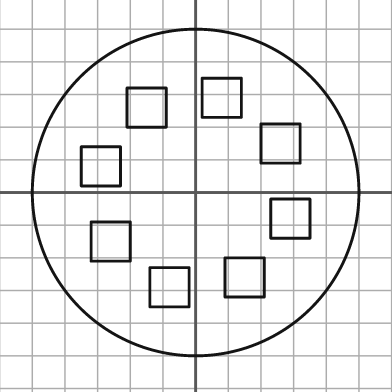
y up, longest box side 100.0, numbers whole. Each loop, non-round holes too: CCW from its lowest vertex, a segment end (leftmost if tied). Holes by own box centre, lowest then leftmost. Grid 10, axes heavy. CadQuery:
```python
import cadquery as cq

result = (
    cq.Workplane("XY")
    .moveTo(0.0, 0.0)
    .circle(50.0)
    .moveTo(-14.0, -35.0)
    .lineTo(-2.0, -35.0)
    .lineTo(-2.0, -23.0)
    .lineTo(-14.0, -23.0)
    .close()
    .moveTo(9.0, -32.0)
    .lineTo(21.0, -32.0)
    .lineTo(21.0, -20.0)
    .lineTo(9.0, -20.0)
    .close()
    .moveTo(-32.0, -21.0)
    .lineTo(-20.0, -21.0)
    .lineTo(-20.0, -9.0)
    .lineTo(-32.0, -9.0)
    .close()
    .moveTo(23.0, -14.0)
    .lineTo(35.0, -14.0)
    .lineTo(35.0, -2.0)
    .lineTo(23.0, -2.0)
    .close()
    .moveTo(-35.0, 2.0)
    .lineTo(-23.0, 2.0)
    .lineTo(-23.0, 14.0)
    .lineTo(-35.0, 14.0)
    .close()
    .moveTo(20.0, 9.0)
    .lineTo(32.0, 9.0)
    .lineTo(32.0, 21.0)
    .lineTo(20.0, 21.0)
    .close()
    .moveTo(-21.0, 20.0)
    .lineTo(-9.0, 20.0)
    .lineTo(-9.0, 32.0)
    .lineTo(-21.0, 32.0)
    .close()
    .moveTo(2.0, 23.0)
    .lineTo(14.0, 23.0)
    .lineTo(14.0, 35.0)
    .lineTo(2.0, 35.0)
    .close()
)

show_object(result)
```